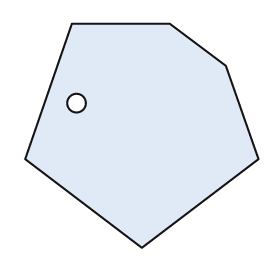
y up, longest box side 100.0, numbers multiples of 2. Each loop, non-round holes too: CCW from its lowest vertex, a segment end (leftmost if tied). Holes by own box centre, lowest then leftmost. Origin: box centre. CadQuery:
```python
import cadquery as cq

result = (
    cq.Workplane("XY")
    .moveTo(0.0, -48.0)
    .lineTo(50.0, -10.0)
    .lineTo(36.0, 30.0)
    .lineTo(12.0, 48.0)
    .lineTo(-30.0, 48.0)
    .lineTo(-50.0, -10.0)
    .close()
    .moveTo(-28.0, 14.0)
    .circle(4.0)
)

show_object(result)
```